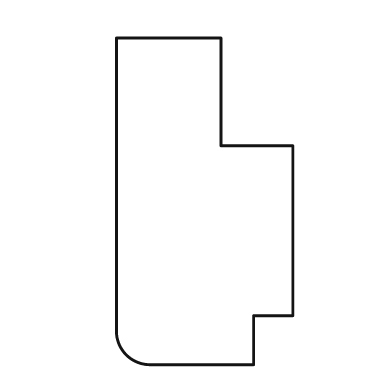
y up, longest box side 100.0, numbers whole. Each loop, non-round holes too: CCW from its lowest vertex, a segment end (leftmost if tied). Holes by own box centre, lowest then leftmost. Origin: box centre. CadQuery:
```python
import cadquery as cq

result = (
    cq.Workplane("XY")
    .moveTo(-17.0, -50.0)
    .lineTo(15.0, -50.0)
    .lineTo(15.0, -35.0)
    .lineTo(27.0, -35.0)
    .lineTo(27.0, 17.0)
    .lineTo(5.0, 17.0)
    .lineTo(5.0, 50.0)
    .lineTo(-27.0, 50.0)
    .lineTo(-27.0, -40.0)
    .threePointArc((-24.0, -47.0), (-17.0, -50.0))
    .close()
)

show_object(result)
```